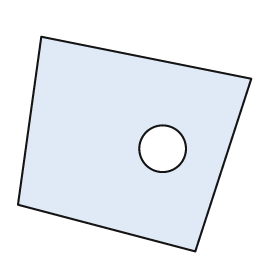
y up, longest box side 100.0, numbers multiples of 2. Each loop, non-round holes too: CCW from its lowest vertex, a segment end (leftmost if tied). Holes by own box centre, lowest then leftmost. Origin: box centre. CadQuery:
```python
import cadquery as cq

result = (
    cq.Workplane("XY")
    .moveTo(26.0, -46.0)
    .lineTo(50.0, 28.0)
    .lineTo(-40.0, 46.0)
    .lineTo(-50.0, -26.0)
    .close()
    .moveTo(12.0, -2.0)
    .circle(10.0)
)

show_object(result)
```